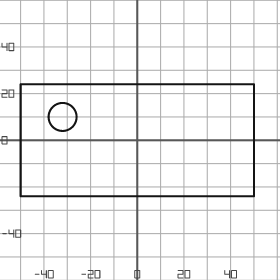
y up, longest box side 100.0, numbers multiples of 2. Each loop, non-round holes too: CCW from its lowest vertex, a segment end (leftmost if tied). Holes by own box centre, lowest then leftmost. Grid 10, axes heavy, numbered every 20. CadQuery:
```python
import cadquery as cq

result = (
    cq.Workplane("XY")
    .moveTo(-50.0, -24.0)
    .lineTo(50.0, -24.0)
    .lineTo(50.0, 24.0)
    .lineTo(-50.0, 24.0)
    .close()
    .moveTo(-32.0, 10.0)
    .circle(6.0)
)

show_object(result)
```